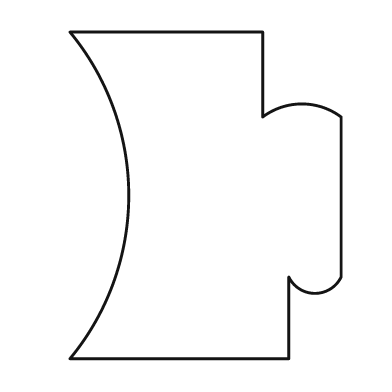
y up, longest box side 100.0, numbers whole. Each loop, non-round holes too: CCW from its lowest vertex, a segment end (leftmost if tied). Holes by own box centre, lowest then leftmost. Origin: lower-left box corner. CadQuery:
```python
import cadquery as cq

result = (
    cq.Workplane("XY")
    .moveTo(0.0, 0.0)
    .lineTo(67.0, 0.0)
    .lineTo(67.0, 25.0)
    .threePointArc((75.0, 20.0), (83.0, 25.0))
    .lineTo(83.0, 74.0)
    .threePointArc((71.0, 78.0), (59.0, 74.0))
    .lineTo(59.0, 100.0)
    .lineTo(0.0, 100.0)
    .threePointArc((18.0, 50.0), (0.0, 0.0))
    .close()
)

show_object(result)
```